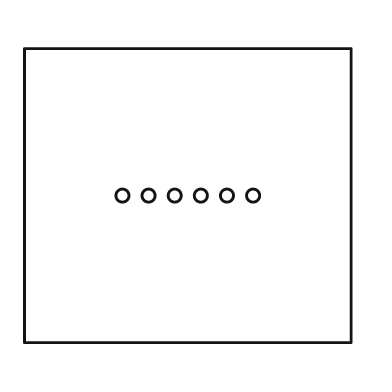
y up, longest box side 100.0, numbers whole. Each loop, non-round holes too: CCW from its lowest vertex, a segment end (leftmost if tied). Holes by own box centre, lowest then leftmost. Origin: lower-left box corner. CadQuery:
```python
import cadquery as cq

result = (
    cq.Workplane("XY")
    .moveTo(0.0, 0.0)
    .lineTo(100.0, 0.0)
    .lineTo(100.0, 90.0)
    .lineTo(0.0, 90.0)
    .close()
    .moveTo(30.0, 45.0)
    .circle(2.0)
    .moveTo(38.0, 45.0)
    .circle(2.0)
    .moveTo(46.0, 45.0)
    .circle(2.0)
    .moveTo(54.0, 45.0)
    .circle(2.0)
    .moveTo(62.0, 45.0)
    .circle(2.0)
    .moveTo(70.0, 45.0)
    .circle(2.0)
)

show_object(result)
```